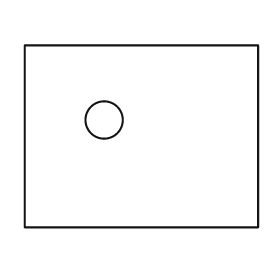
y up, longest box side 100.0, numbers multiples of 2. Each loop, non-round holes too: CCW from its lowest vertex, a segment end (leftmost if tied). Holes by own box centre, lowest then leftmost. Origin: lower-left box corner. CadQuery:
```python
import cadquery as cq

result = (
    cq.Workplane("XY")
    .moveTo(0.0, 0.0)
    .lineTo(100.0, 0.0)
    .lineTo(100.0, 78.0)
    .lineTo(0.0, 78.0)
    .close()
    .moveTo(34.0, 46.0)
    .circle(8.0)
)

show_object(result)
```